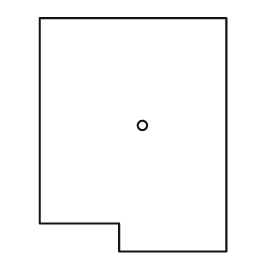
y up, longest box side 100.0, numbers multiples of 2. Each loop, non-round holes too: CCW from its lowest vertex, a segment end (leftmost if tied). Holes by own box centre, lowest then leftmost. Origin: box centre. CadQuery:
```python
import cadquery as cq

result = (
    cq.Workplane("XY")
    .moveTo(-6.0, -50.0)
    .lineTo(40.0, -50.0)
    .lineTo(40.0, 50.0)
    .lineTo(-40.0, 50.0)
    .lineTo(-40.0, -38.0)
    .lineTo(-6.0, -38.0)
    .close()
    .moveTo(4.0, 4.0)
    .circle(2.0)
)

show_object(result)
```